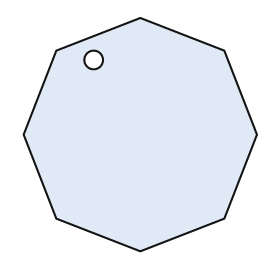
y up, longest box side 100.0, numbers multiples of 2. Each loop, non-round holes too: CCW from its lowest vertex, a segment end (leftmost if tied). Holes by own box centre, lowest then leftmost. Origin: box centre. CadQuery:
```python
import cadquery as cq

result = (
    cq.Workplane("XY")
    .moveTo(0.0, -50.0)
    .lineTo(36.0, -36.0)
    .lineTo(50.0, 0.0)
    .lineTo(36.0, 36.0)
    .lineTo(0.0, 50.0)
    .lineTo(-36.0, 36.0)
    .lineTo(-50.0, 0.0)
    .lineTo(-36.0, -36.0)
    .close()
    .moveTo(-20.0, 32.0)
    .circle(4.0)
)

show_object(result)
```